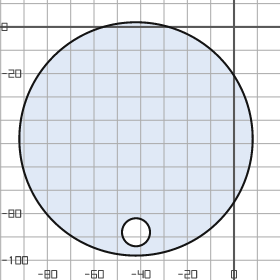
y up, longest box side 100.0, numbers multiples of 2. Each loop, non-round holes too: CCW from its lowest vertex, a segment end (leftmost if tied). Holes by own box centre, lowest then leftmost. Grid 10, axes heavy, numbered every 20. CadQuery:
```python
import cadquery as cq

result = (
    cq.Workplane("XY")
    .moveTo(-42.0, -48.0)
    .circle(50.0)
    .moveTo(-42.0, -88.0)
    .circle(6.0)
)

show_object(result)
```